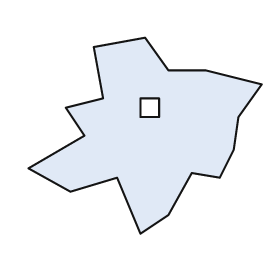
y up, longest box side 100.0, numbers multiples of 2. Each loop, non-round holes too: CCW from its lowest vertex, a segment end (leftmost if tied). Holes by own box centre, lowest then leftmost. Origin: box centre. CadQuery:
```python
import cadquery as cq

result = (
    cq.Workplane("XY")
    .moveTo(-2.0, -42.0)
    .lineTo(10.0, -34.0)
    .lineTo(20.0, -16.0)
    .lineTo(32.0, -18.0)
    .lineTo(38.0, -6.0)
    .lineTo(40.0, 8.0)
    .lineTo(50.0, 22.0)
    .lineTo(26.0, 28.0)
    .lineTo(10.0, 28.0)
    .lineTo(0.0, 42.0)
    .lineTo(-22.0, 38.0)
    .lineTo(-18.0, 16.0)
    .lineTo(-34.0, 12.0)
    .lineTo(-26.0, 0.0)
    .lineTo(-50.0, -14.0)
    .lineTo(-32.0, -24.0)
    .lineTo(-12.0, -18.0)
    .close()
    .moveTo(-2.0, 8.0)
    .lineTo(6.0, 8.0)
    .lineTo(6.0, 16.0)
    .lineTo(-2.0, 16.0)
    .close()
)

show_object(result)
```